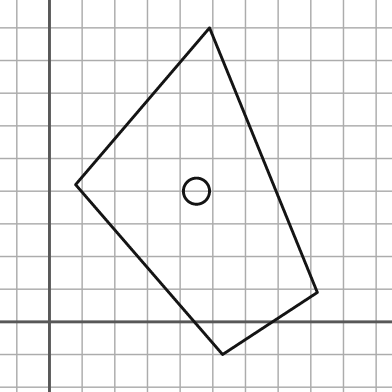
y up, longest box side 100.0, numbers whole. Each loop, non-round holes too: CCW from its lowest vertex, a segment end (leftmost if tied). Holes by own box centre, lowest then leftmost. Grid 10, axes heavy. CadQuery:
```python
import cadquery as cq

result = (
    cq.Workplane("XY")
    .moveTo(53.0, -10.0)
    .lineTo(82.0, 9.0)
    .lineTo(49.0, 90.0)
    .lineTo(8.0, 42.0)
    .close()
    .moveTo(45.0, 40.0)
    .circle(4.0)
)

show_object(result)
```